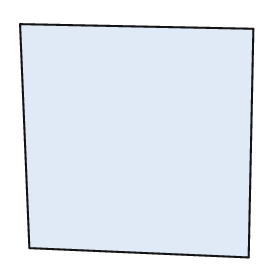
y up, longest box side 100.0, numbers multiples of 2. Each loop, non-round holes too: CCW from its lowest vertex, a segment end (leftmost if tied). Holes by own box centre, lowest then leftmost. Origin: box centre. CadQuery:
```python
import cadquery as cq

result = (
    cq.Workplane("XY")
    .moveTo(48.0, -50.0)
    .lineTo(50.0, 48.0)
    .lineTo(-50.0, 50.0)
    .lineTo(-46.0, -46.0)
    .close()
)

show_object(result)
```